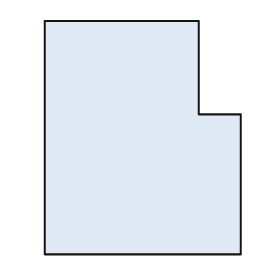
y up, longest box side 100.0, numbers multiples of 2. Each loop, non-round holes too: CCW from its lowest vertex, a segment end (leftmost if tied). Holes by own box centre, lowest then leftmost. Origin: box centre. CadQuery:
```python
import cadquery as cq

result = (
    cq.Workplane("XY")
    .moveTo(-42.0, -50.0)
    .lineTo(42.0, -50.0)
    .lineTo(42.0, 10.0)
    .lineTo(24.0, 10.0)
    .lineTo(24.0, 50.0)
    .lineTo(-42.0, 50.0)
    .close()
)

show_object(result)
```